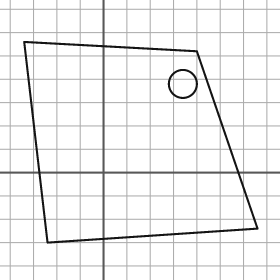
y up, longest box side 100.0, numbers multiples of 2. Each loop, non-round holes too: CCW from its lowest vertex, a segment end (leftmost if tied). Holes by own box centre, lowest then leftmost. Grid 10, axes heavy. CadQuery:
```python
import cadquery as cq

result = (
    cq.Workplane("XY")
    .moveTo(-24.0, -30.0)
    .lineTo(66.0, -24.0)
    .lineTo(40.0, 52.0)
    .lineTo(-34.0, 56.0)
    .close()
    .moveTo(34.0, 38.0)
    .circle(6.0)
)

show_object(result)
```